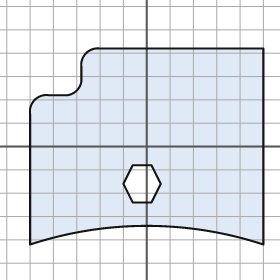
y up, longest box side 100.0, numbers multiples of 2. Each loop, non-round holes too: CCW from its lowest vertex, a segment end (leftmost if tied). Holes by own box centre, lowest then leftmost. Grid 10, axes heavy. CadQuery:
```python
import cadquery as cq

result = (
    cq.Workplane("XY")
    .moveTo(-50.0, -42.0)
    .threePointArc((0.0, -34.0), (50.0, -42.0))
    .lineTo(50.0, 42.0)
    .lineTo(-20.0, 42.0)
    .threePointArc((-26.0, 40.0), (-28.0, 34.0))
    .lineTo(-28.0, 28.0)
    .threePointArc((-30.0, 24.0), (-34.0, 22.0))
    .lineTo(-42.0, 22.0)
    .threePointArc((-48.0, 20.0), (-50.0, 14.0))
    .close()
    .moveTo(-6.0, -24.0)
    .lineTo(2.0, -24.0)
    .lineTo(6.0, -16.0)
    .lineTo(2.0, -8.0)
    .lineTo(-6.0, -8.0)
    .lineTo(-10.0, -16.0)
    .close()
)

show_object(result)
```